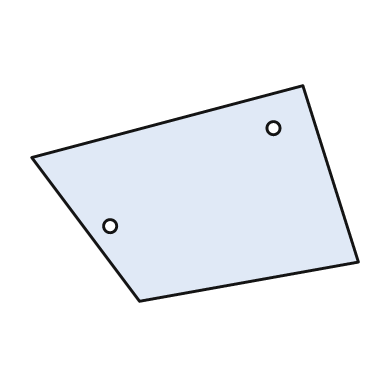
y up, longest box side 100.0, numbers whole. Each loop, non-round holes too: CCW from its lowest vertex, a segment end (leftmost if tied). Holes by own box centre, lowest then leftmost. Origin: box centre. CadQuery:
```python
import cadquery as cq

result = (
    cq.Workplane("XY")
    .moveTo(-17.0, -33.0)
    .lineTo(50.0, -21.0)
    .lineTo(33.0, 33.0)
    .lineTo(-50.0, 11.0)
    .close()
    .moveTo(-26.0, -10.0)
    .circle(2.0)
    .moveTo(24.0, 20.0)
    .circle(2.0)
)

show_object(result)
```